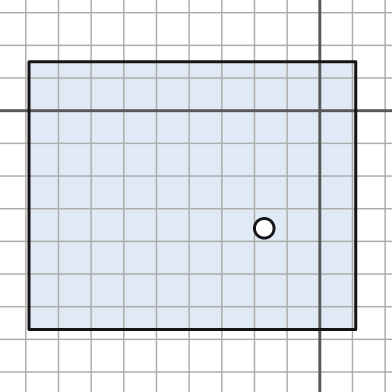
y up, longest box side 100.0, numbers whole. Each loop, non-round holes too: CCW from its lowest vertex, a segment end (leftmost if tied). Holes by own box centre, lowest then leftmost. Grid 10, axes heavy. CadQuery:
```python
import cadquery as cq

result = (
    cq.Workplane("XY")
    .moveTo(-89.0, -67.0)
    .lineTo(11.0, -67.0)
    .lineTo(11.0, 15.0)
    .lineTo(-89.0, 15.0)
    .close()
    .moveTo(-17.0, -36.0)
    .circle(3.0)
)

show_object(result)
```